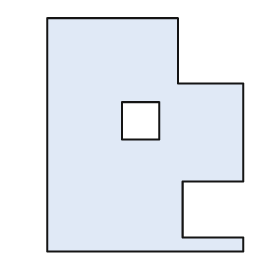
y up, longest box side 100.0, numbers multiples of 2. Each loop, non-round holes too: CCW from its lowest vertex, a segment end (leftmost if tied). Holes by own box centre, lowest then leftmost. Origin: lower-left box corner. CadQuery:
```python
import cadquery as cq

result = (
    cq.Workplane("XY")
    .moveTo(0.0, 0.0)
    .lineTo(84.0, 0.0)
    .lineTo(84.0, 6.0)
    .lineTo(58.0, 6.0)
    .lineTo(58.0, 30.0)
    .lineTo(84.0, 30.0)
    .lineTo(84.0, 72.0)
    .lineTo(56.0, 72.0)
    .lineTo(56.0, 100.0)
    .lineTo(0.0, 100.0)
    .close()
    .moveTo(32.0, 48.0)
    .lineTo(48.0, 48.0)
    .lineTo(48.0, 64.0)
    .lineTo(32.0, 64.0)
    .close()
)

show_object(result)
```